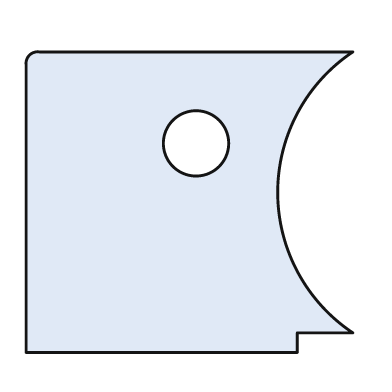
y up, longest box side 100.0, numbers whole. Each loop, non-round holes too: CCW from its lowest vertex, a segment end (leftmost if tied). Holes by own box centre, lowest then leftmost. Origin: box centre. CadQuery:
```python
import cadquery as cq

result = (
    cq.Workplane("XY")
    .moveTo(-50.0, -46.0)
    .lineTo(33.0, -46.0)
    .lineTo(33.0, -40.0)
    .lineTo(50.0, -40.0)
    .threePointArc((27.0, 3.0), (50.0, 46.0))
    .lineTo(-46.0, 46.0)
    .threePointArc((-49.0, 45.0), (-50.0, 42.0))
    .close()
    .moveTo(2.0, 18.0)
    .circle(10.0)
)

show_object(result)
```